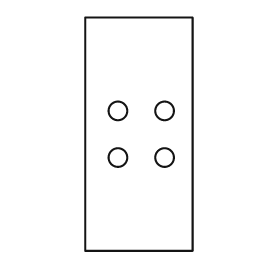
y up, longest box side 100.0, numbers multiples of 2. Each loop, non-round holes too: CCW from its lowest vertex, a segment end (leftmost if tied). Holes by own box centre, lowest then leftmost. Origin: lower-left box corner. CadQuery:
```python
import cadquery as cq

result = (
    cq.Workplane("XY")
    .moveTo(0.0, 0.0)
    .lineTo(46.0, 0.0)
    .lineTo(46.0, 100.0)
    .lineTo(0.0, 100.0)
    .close()
    .moveTo(14.0, 40.0)
    .circle(4.0)
    .moveTo(34.0, 40.0)
    .circle(4.0)
    .moveTo(14.0, 60.0)
    .circle(4.0)
    .moveTo(34.0, 60.0)
    .circle(4.0)
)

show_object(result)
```